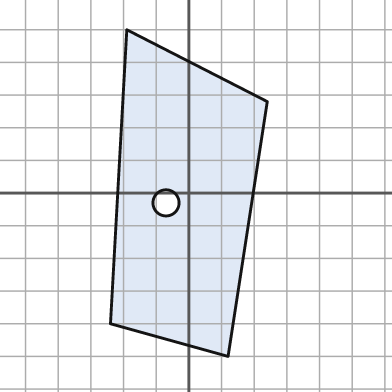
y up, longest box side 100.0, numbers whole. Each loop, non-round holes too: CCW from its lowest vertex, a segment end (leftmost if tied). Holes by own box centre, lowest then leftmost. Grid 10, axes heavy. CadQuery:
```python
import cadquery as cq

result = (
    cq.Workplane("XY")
    .moveTo(12.0, -50.0)
    .lineTo(24.0, 28.0)
    .lineTo(-19.0, 50.0)
    .lineTo(-24.0, -40.0)
    .close()
    .moveTo(-7.0, -3.0)
    .circle(4.0)
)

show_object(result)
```